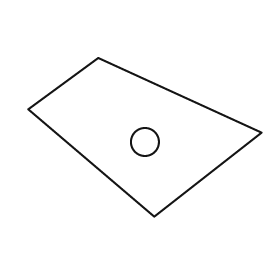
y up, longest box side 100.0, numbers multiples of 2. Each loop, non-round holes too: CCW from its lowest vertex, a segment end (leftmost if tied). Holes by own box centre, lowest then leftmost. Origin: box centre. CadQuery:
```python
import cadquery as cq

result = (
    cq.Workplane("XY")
    .moveTo(4.0, -34.0)
    .lineTo(50.0, 2.0)
    .lineTo(-20.0, 34.0)
    .lineTo(-50.0, 12.0)
    .close()
    .moveTo(0.0, -2.0)
    .circle(6.0)
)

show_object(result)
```